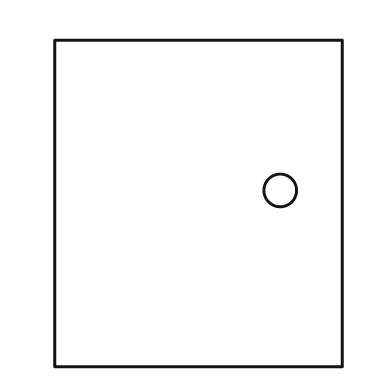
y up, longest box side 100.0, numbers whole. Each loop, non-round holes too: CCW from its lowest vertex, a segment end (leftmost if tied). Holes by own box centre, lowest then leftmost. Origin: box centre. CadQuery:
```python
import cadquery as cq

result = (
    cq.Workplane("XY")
    .moveTo(-44.0, -50.0)
    .lineTo(44.0, -50.0)
    .lineTo(44.0, 50.0)
    .lineTo(-44.0, 50.0)
    .close()
    .moveTo(25.0, 4.0)
    .circle(5.0)
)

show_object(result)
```